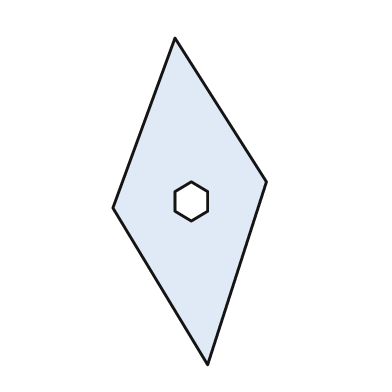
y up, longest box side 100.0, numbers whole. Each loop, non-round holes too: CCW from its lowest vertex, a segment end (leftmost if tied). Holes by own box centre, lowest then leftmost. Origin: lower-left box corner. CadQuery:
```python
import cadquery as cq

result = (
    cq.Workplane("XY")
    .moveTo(29.0, 0.0)
    .lineTo(47.0, 56.0)
    .lineTo(19.0, 100.0)
    .lineTo(0.0, 48.0)
    .close()
    .moveTo(24.0, 44.0)
    .lineTo(29.0, 47.0)
    .lineTo(29.0, 53.0)
    .lineTo(24.0, 56.0)
    .lineTo(19.0, 53.0)
    .lineTo(19.0, 47.0)
    .close()
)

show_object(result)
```